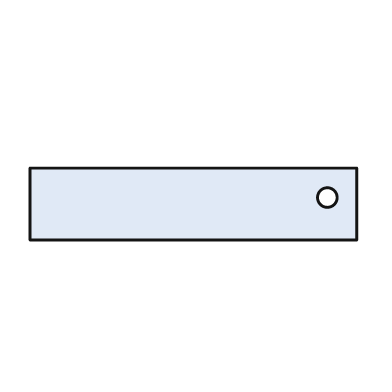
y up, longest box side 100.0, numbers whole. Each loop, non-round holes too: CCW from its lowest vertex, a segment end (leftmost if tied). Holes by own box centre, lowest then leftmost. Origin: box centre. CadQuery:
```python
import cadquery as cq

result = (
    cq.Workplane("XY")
    .moveTo(-50.0, -11.0)
    .lineTo(50.0, -11.0)
    .lineTo(50.0, 11.0)
    .lineTo(-50.0, 11.0)
    .close()
    .moveTo(41.0, 2.0)
    .circle(3.0)
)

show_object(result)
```